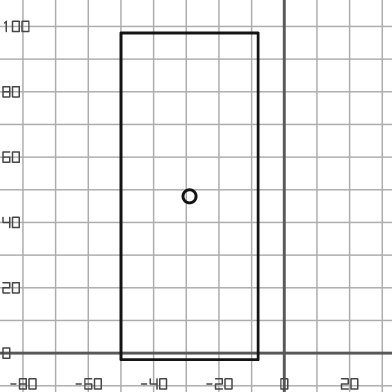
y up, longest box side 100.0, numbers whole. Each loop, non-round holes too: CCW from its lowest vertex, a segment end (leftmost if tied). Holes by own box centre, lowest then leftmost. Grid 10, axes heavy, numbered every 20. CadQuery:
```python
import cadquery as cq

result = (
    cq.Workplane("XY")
    .moveTo(-50.0, -2.0)
    .lineTo(-8.0, -2.0)
    .lineTo(-8.0, 98.0)
    .lineTo(-50.0, 98.0)
    .close()
    .moveTo(-29.0, 48.0)
    .circle(2.0)
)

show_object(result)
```